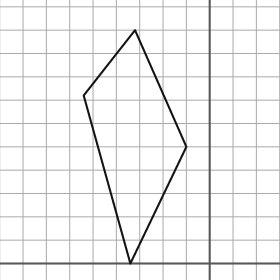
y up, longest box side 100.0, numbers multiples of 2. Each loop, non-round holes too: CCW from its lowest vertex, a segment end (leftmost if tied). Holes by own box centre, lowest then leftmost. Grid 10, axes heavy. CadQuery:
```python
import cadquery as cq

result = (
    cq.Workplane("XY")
    .moveTo(-34.0, 0.0)
    .lineTo(-10.0, 50.0)
    .lineTo(-32.0, 100.0)
    .lineTo(-54.0, 72.0)
    .close()
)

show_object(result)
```